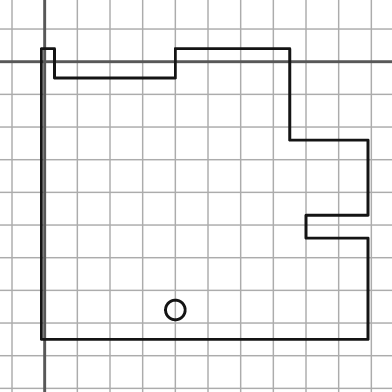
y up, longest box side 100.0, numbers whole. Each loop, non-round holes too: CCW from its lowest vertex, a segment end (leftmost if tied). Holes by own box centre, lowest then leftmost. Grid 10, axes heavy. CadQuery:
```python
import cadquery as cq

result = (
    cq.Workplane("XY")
    .moveTo(-1.0, -85.0)
    .lineTo(99.0, -85.0)
    .lineTo(99.0, -54.0)
    .lineTo(80.0, -54.0)
    .lineTo(80.0, -47.0)
    .lineTo(99.0, -47.0)
    .lineTo(99.0, -24.0)
    .lineTo(75.0, -24.0)
    .lineTo(75.0, 4.0)
    .lineTo(40.0, 4.0)
    .lineTo(40.0, -5.0)
    .lineTo(3.0, -5.0)
    .lineTo(3.0, 4.0)
    .lineTo(-1.0, 4.0)
    .close()
    .moveTo(40.0, -76.0)
    .circle(3.0)
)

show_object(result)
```